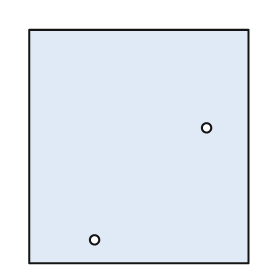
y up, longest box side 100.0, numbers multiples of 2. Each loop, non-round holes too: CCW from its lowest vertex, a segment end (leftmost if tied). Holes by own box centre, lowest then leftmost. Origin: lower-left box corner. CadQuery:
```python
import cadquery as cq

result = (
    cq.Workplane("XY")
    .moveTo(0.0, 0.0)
    .lineTo(94.0, 0.0)
    .lineTo(94.0, 100.0)
    .lineTo(0.0, 100.0)
    .close()
    .moveTo(28.0, 10.0)
    .circle(2.0)
    .moveTo(76.0, 58.0)
    .circle(2.0)
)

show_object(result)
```